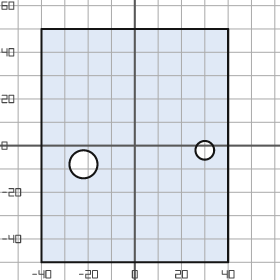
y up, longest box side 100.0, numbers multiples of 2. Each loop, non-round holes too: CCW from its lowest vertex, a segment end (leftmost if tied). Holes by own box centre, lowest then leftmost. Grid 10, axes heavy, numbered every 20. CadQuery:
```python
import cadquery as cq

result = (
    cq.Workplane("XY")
    .moveTo(-40.0, -50.0)
    .lineTo(40.0, -50.0)
    .lineTo(40.0, 50.0)
    .lineTo(-40.0, 50.0)
    .close()
    .moveTo(-22.0, -8.0)
    .circle(6.0)
    .moveTo(30.0, -2.0)
    .circle(4.0)
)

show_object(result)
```